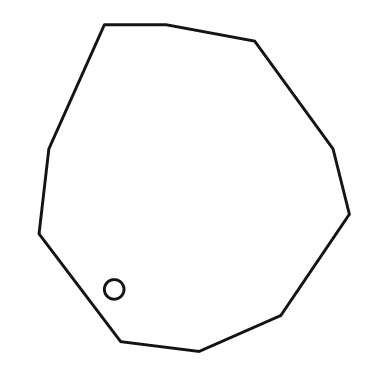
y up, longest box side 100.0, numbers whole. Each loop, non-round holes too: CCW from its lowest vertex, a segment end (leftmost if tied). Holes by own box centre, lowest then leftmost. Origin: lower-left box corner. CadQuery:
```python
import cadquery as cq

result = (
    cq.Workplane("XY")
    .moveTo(49.0, 0.0)
    .lineTo(74.0, 11.0)
    .lineTo(95.0, 42.0)
    .lineTo(90.0, 62.0)
    .lineTo(66.0, 95.0)
    .lineTo(39.0, 100.0)
    .lineTo(20.0, 100.0)
    .lineTo(3.0, 62.0)
    .lineTo(0.0, 36.0)
    .lineTo(25.0, 3.0)
    .close()
    .moveTo(23.0, 19.0)
    .circle(3.0)
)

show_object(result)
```